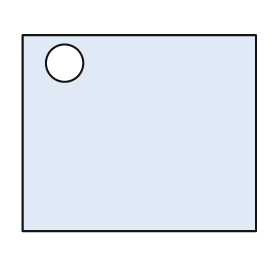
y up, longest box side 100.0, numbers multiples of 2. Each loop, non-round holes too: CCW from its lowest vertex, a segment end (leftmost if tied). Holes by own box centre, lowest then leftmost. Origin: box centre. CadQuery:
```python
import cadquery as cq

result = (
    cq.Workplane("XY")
    .moveTo(-50.0, -42.0)
    .lineTo(50.0, -42.0)
    .lineTo(50.0, 42.0)
    .lineTo(-50.0, 42.0)
    .close()
    .moveTo(-32.0, 30.0)
    .circle(8.0)
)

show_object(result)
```